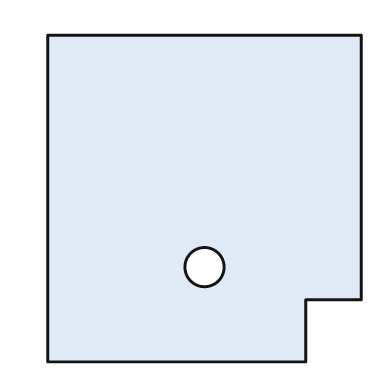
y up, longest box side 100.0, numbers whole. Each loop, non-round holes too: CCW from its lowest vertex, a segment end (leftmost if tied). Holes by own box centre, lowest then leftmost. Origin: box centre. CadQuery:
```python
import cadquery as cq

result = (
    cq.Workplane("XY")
    .moveTo(-48.0, -50.0)
    .lineTo(31.0, -50.0)
    .lineTo(31.0, -31.0)
    .lineTo(48.0, -31.0)
    .lineTo(48.0, 50.0)
    .lineTo(-48.0, 50.0)
    .close()
    .moveTo(0.0, -21.0)
    .circle(6.0)
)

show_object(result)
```